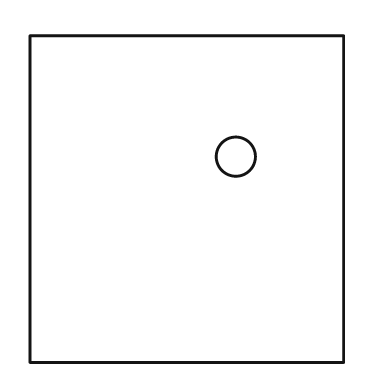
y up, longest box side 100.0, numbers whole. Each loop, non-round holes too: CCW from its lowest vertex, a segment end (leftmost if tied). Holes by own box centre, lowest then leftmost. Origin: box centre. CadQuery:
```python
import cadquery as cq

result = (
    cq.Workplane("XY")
    .moveTo(-48.0, -50.0)
    .lineTo(48.0, -50.0)
    .lineTo(48.0, 50.0)
    .lineTo(-48.0, 50.0)
    .close()
    .moveTo(15.0, 13.0)
    .circle(6.0)
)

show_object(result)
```